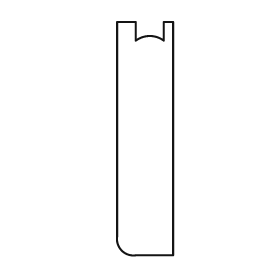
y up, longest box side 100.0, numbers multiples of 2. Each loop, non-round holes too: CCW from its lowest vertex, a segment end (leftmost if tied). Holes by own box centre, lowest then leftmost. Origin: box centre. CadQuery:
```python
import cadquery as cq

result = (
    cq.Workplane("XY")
    .moveTo(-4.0, -50.0)
    .lineTo(12.0, -50.0)
    .lineTo(12.0, 50.0)
    .lineTo(8.0, 50.0)
    .lineTo(8.0, 42.0)
    .threePointArc((2.0, 44.0), (-4.0, 42.0))
    .lineTo(-4.0, 50.0)
    .lineTo(-12.0, 50.0)
    .lineTo(-12.0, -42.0)
    .threePointArc((-10.0, -48.0), (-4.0, -50.0))
    .close()
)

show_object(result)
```